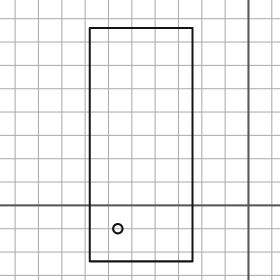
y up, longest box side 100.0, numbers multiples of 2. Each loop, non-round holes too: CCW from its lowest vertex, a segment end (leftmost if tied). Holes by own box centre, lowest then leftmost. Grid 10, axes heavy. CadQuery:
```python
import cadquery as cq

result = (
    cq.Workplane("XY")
    .moveTo(-68.0, -24.0)
    .lineTo(-24.0, -24.0)
    .lineTo(-24.0, 76.0)
    .lineTo(-68.0, 76.0)
    .close()
    .moveTo(-56.0, -10.0)
    .circle(2.0)
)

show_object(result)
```